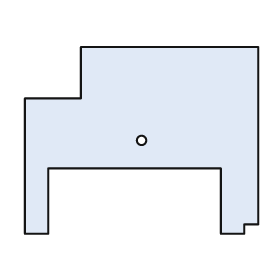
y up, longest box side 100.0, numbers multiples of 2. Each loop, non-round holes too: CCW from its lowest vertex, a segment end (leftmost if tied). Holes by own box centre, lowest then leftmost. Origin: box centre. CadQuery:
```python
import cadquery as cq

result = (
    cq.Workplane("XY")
    .moveTo(-50.0, -40.0)
    .lineTo(-40.0, -40.0)
    .lineTo(-40.0, -12.0)
    .lineTo(34.0, -12.0)
    .lineTo(34.0, -40.0)
    .lineTo(44.0, -40.0)
    .lineTo(44.0, -36.0)
    .lineTo(50.0, -36.0)
    .lineTo(50.0, 40.0)
    .lineTo(-26.0, 40.0)
    .lineTo(-26.0, 18.0)
    .lineTo(-50.0, 18.0)
    .close()
    .moveTo(0.0, 0.0)
    .circle(2.0)
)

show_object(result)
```